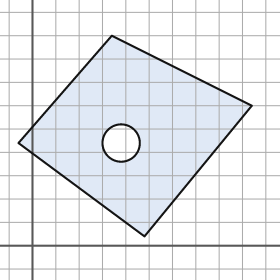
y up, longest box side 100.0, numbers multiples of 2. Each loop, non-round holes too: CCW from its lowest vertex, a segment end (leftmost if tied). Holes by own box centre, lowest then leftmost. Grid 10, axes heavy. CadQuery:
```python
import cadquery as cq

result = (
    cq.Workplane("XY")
    .moveTo(48.0, 4.0)
    .lineTo(94.0, 60.0)
    .lineTo(34.0, 90.0)
    .lineTo(-6.0, 44.0)
    .close()
    .moveTo(38.0, 44.0)
    .circle(8.0)
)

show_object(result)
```